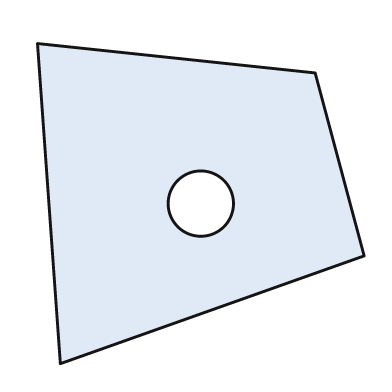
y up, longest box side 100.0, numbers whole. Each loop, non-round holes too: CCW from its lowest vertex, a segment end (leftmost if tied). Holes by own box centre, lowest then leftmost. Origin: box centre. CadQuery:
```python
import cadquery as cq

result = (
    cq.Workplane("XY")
    .moveTo(-43.0, -49.0)
    .lineTo(50.0, -16.0)
    .lineTo(35.0, 40.0)
    .lineTo(-50.0, 49.0)
    .close()
    .moveTo(0.0, 0.0)
    .circle(10.0)
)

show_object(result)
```